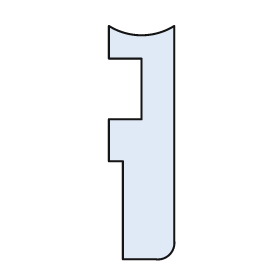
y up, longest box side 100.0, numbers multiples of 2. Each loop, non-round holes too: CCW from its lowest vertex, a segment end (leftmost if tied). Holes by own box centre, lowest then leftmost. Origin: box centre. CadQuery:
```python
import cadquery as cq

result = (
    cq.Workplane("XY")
    .moveTo(-8.0, -50.0)
    .lineTo(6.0, -50.0)
    .threePointArc((12.0, -48.0), (14.0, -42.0))
    .lineTo(14.0, 50.0)
    .threePointArc((0.0, 46.0), (-14.0, 50.0))
    .lineTo(-14.0, 36.0)
    .lineTo(0.0, 36.0)
    .lineTo(0.0, 10.0)
    .lineTo(-14.0, 10.0)
    .lineTo(-14.0, -8.0)
    .lineTo(-8.0, -8.0)
    .close()
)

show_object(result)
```